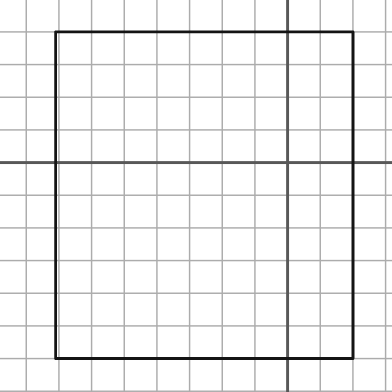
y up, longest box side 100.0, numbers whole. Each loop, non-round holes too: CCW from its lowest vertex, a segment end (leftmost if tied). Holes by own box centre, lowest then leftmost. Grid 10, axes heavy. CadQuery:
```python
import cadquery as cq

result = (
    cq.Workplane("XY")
    .moveTo(-71.0, -60.0)
    .lineTo(20.0, -60.0)
    .lineTo(20.0, 40.0)
    .lineTo(-71.0, 40.0)
    .close()
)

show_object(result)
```